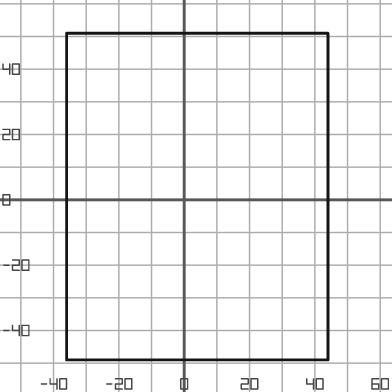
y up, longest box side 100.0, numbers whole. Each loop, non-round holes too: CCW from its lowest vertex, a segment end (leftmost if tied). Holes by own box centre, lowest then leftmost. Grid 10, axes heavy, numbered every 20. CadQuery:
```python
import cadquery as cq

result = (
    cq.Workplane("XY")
    .moveTo(-36.0, -49.0)
    .lineTo(44.0, -49.0)
    .lineTo(44.0, 51.0)
    .lineTo(-36.0, 51.0)
    .close()
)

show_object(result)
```